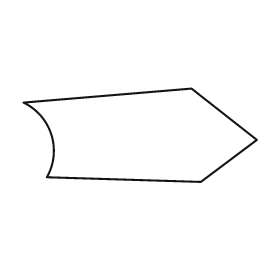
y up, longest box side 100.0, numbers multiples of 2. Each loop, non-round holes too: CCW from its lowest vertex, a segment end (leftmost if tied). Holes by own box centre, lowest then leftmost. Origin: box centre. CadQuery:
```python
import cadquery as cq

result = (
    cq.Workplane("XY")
    .moveTo(26.0, -20.0)
    .lineTo(50.0, -2.0)
    .lineTo(22.0, 20.0)
    .lineTo(-50.0, 14.0)
    .threePointArc((-38.0, 0.0), (-40.0, -18.0))
    .close()
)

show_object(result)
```